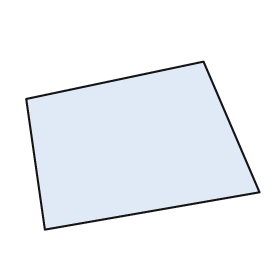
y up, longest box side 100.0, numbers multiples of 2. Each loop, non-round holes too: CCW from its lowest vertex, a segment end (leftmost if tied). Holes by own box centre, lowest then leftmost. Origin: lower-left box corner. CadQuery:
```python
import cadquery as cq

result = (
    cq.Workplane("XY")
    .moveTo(8.0, 0.0)
    .lineTo(100.0, 16.0)
    .lineTo(76.0, 72.0)
    .lineTo(0.0, 56.0)
    .close()
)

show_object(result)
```